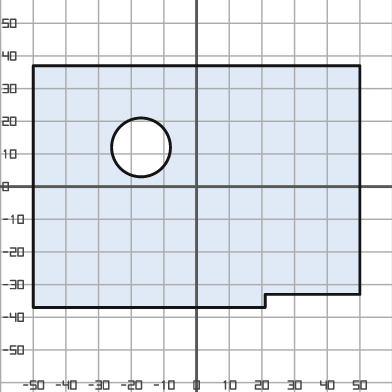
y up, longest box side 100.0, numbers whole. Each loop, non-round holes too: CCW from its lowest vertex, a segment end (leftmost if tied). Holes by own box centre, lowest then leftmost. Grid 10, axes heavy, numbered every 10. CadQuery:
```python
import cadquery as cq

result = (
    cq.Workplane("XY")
    .moveTo(-50.0, -37.0)
    .lineTo(21.0, -37.0)
    .lineTo(21.0, -33.0)
    .lineTo(50.0, -33.0)
    .lineTo(50.0, 37.0)
    .lineTo(-50.0, 37.0)
    .close()
    .moveTo(-17.0, 12.0)
    .circle(9.0)
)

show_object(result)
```